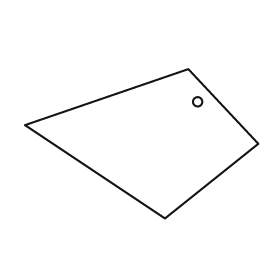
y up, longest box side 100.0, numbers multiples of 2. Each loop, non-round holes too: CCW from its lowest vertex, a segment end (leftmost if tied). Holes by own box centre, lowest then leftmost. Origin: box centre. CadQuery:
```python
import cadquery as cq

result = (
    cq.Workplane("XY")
    .moveTo(10.0, -32.0)
    .lineTo(50.0, 0.0)
    .lineTo(20.0, 32.0)
    .lineTo(-50.0, 8.0)
    .close()
    .moveTo(24.0, 18.0)
    .circle(2.0)
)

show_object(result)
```